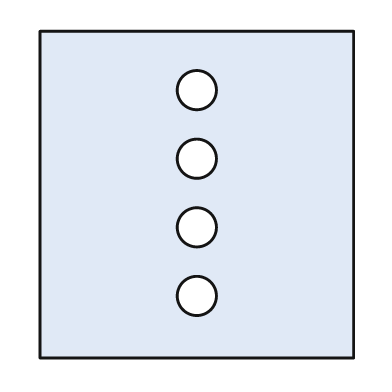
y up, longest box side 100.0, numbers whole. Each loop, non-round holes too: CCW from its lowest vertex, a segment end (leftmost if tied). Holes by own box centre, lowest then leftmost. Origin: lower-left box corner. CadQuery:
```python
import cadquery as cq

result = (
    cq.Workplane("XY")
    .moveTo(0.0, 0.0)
    .lineTo(96.0, 0.0)
    .lineTo(96.0, 100.0)
    .lineTo(0.0, 100.0)
    .close()
    .moveTo(48.0, 19.0)
    .circle(6.0)
    .moveTo(48.0, 40.0)
    .circle(6.0)
    .moveTo(48.0, 61.0)
    .circle(6.0)
    .moveTo(48.0, 82.0)
    .circle(6.0)
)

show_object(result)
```